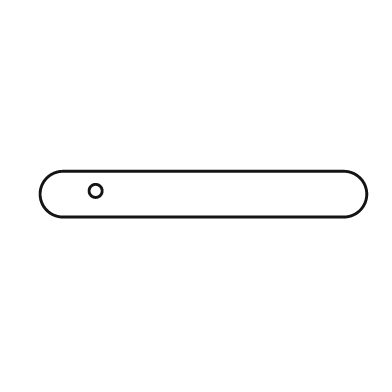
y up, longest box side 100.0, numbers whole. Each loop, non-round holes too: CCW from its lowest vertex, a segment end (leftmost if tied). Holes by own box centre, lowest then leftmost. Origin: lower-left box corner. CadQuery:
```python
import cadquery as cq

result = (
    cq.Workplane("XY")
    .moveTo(7.0, 0.0)
    .lineTo(93.0, 0.0)
    .threePointArc((100.0, 7.0), (93.0, 14.0))
    .lineTo(7.0, 14.0)
    .threePointArc((0.0, 7.0), (7.0, 0.0))
    .close()
    .moveTo(17.0, 8.0)
    .circle(2.0)
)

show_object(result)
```